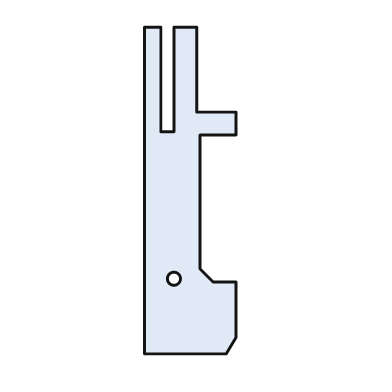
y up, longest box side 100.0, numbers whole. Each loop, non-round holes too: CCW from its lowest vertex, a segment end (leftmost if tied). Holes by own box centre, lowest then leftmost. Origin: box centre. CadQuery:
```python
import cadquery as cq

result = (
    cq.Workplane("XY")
    .moveTo(-14.0, -50.0)
    .lineTo(11.0, -50.0)
    .lineTo(14.0, -45.0)
    .lineTo(14.0, -28.0)
    .lineTo(7.0, -28.0)
    .lineTo(3.0, -24.0)
    .lineTo(3.0, 17.0)
    .lineTo(14.0, 17.0)
    .lineTo(14.0, 24.0)
    .lineTo(2.0, 24.0)
    .lineTo(2.0, 50.0)
    .lineTo(-5.0, 50.0)
    .lineTo(-5.0, 18.0)
    .lineTo(-9.0, 18.0)
    .lineTo(-9.0, 50.0)
    .lineTo(-14.0, 50.0)
    .close()
    .moveTo(-5.0, -27.0)
    .circle(2.0)
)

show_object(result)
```